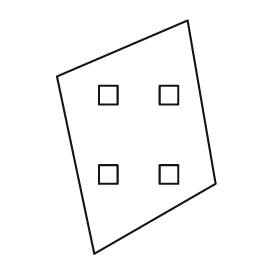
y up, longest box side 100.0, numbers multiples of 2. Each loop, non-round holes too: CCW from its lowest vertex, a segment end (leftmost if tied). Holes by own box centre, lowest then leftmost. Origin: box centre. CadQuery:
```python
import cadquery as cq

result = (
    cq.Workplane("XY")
    .moveTo(-18.0, -50.0)
    .lineTo(34.0, -20.0)
    .lineTo(22.0, 50.0)
    .lineTo(-34.0, 26.0)
    .close()
    .moveTo(-16.0, -20.0)
    .lineTo(-8.0, -20.0)
    .lineTo(-8.0, -12.0)
    .lineTo(-16.0, -12.0)
    .close()
    .moveTo(10.0, -20.0)
    .lineTo(18.0, -20.0)
    .lineTo(18.0, -12.0)
    .lineTo(10.0, -12.0)
    .close()
    .moveTo(-16.0, 14.0)
    .lineTo(-8.0, 14.0)
    .lineTo(-8.0, 22.0)
    .lineTo(-16.0, 22.0)
    .close()
    .moveTo(10.0, 14.0)
    .lineTo(18.0, 14.0)
    .lineTo(18.0, 22.0)
    .lineTo(10.0, 22.0)
    .close()
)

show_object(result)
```